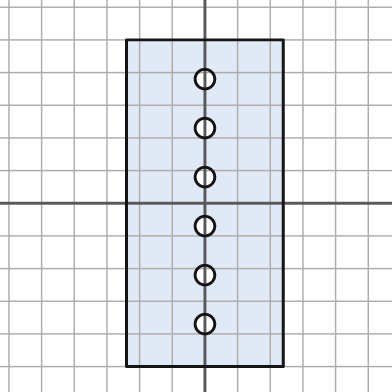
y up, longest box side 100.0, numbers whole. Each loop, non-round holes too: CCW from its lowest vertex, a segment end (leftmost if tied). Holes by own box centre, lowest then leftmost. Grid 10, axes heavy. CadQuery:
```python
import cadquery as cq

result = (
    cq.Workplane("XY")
    .moveTo(-24.0, -50.0)
    .lineTo(24.0, -50.0)
    .lineTo(24.0, 50.0)
    .lineTo(-24.0, 50.0)
    .close()
    .moveTo(0.0, -37.0)
    .circle(3.0)
    .moveTo(0.0, -22.0)
    .circle(3.0)
    .moveTo(0.0, -7.0)
    .circle(3.0)
    .moveTo(0.0, 8.0)
    .circle(3.0)
    .moveTo(0.0, 23.0)
    .circle(3.0)
    .moveTo(0.0, 38.0)
    .circle(3.0)
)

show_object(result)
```